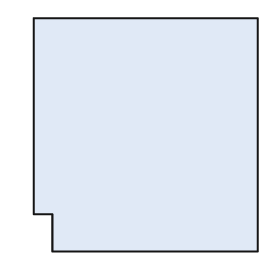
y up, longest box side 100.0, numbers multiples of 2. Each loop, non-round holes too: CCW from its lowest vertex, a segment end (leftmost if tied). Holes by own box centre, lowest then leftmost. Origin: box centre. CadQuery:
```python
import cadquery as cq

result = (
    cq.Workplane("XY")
    .moveTo(-40.0, -50.0)
    .lineTo(48.0, -50.0)
    .lineTo(48.0, 50.0)
    .lineTo(-48.0, 50.0)
    .lineTo(-48.0, -34.0)
    .lineTo(-40.0, -34.0)
    .close()
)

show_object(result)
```